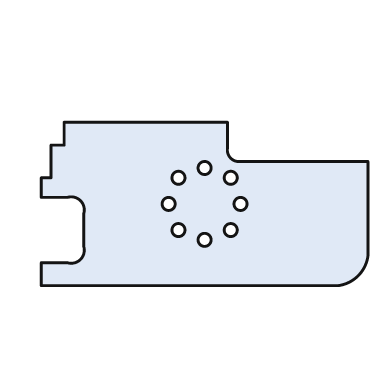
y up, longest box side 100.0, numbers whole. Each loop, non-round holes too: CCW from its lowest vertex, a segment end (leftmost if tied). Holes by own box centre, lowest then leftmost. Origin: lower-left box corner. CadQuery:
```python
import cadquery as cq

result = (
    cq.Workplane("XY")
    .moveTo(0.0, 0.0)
    .lineTo(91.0, 0.0)
    .threePointArc((97.0, 3.0), (100.0, 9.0))
    .lineTo(100.0, 38.0)
    .lineTo(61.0, 38.0)
    .threePointArc((58.0, 39.0), (57.0, 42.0))
    .lineTo(57.0, 50.0)
    .lineTo(7.0, 50.0)
    .lineTo(7.0, 43.0)
    .lineTo(3.0, 43.0)
    .lineTo(3.0, 33.0)
    .lineTo(0.0, 33.0)
    .lineTo(0.0, 27.0)
    .lineTo(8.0, 27.0)
    .threePointArc((12.0, 26.0), (13.0, 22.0))
    .lineTo(13.0, 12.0)
    .threePointArc((12.0, 8.0), (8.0, 7.0))
    .lineTo(0.0, 7.0)
    .close()
    .moveTo(50.0, 14.0)
    .circle(2.0)
    .moveTo(42.0, 17.0)
    .circle(2.0)
    .moveTo(58.0, 17.0)
    .circle(2.0)
    .moveTo(39.0, 25.0)
    .circle(2.0)
    .moveTo(61.0, 25.0)
    .circle(2.0)
    .moveTo(42.0, 33.0)
    .circle(2.0)
    .moveTo(58.0, 33.0)
    .circle(2.0)
    .moveTo(50.0, 36.0)
    .circle(2.0)
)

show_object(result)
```